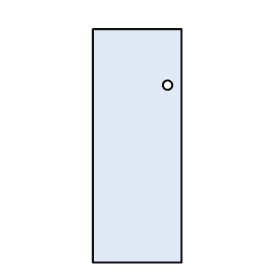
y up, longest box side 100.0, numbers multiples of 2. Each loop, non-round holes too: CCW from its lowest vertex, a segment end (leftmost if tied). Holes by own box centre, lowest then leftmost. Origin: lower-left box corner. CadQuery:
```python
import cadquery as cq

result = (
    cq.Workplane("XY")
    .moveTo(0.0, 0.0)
    .lineTo(38.0, 0.0)
    .lineTo(38.0, 100.0)
    .lineTo(0.0, 100.0)
    .close()
    .moveTo(32.0, 76.0)
    .circle(2.0)
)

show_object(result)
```